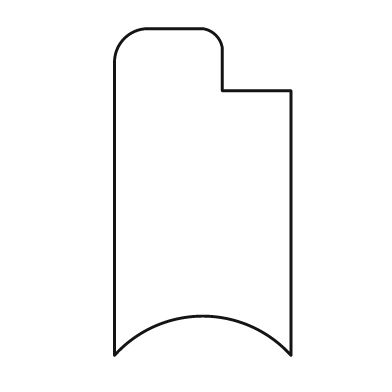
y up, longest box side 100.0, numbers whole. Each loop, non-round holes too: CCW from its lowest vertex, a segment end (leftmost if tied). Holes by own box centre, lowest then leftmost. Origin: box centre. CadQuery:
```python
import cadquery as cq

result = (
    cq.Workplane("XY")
    .moveTo(-27.0, -50.0)
    .threePointArc((0.0, -38.0), (27.0, -50.0))
    .lineTo(27.0, 31.0)
    .lineTo(6.0, 31.0)
    .lineTo(6.0, 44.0)
    .threePointArc((4.0, 48.0), (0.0, 50.0))
    .lineTo(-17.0, 50.0)
    .threePointArc((-24.0, 47.0), (-27.0, 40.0))
    .close()
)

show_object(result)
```